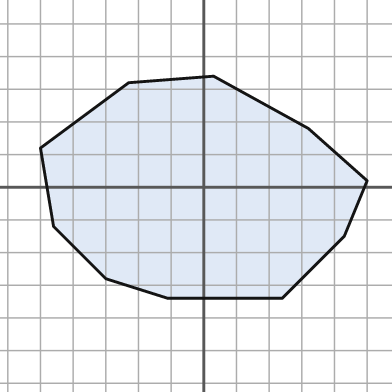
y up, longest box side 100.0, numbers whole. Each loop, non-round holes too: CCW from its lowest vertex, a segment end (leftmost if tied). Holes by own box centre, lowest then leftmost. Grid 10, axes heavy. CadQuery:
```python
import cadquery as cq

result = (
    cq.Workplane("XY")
    .moveTo(-11.0, -34.0)
    .lineTo(24.0, -34.0)
    .lineTo(43.0, -15.0)
    .lineTo(50.0, 2.0)
    .lineTo(32.0, 18.0)
    .lineTo(3.0, 34.0)
    .lineTo(-23.0, 32.0)
    .lineTo(-50.0, 12.0)
    .lineTo(-46.0, -12.0)
    .lineTo(-30.0, -28.0)
    .close()
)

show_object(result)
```